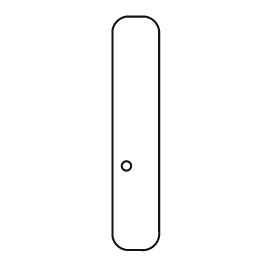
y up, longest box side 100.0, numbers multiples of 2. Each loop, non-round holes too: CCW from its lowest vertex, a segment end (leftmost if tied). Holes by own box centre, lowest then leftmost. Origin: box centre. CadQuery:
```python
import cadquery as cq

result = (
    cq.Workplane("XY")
    .moveTo(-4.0, -50.0)
    .lineTo(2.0, -50.0)
    .threePointArc((8.0, -48.0), (10.0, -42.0))
    .lineTo(10.0, 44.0)
    .threePointArc((8.0, 48.0), (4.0, 50.0))
    .lineTo(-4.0, 50.0)
    .threePointArc((-8.0, 48.0), (-10.0, 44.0))
    .lineTo(-10.0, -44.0)
    .threePointArc((-8.0, -48.0), (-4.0, -50.0))
    .close()
    .moveTo(-4.0, -14.0)
    .circle(2.0)
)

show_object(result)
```